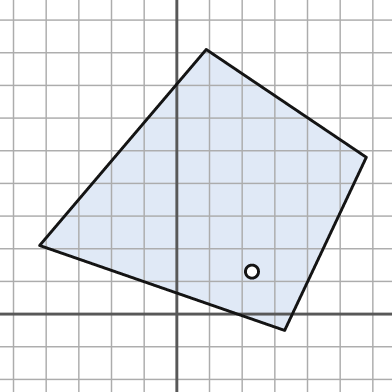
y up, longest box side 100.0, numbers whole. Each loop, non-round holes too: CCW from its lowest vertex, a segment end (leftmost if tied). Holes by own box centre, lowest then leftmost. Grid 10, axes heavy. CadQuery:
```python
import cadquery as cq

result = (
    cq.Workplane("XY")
    .moveTo(33.0, -5.0)
    .lineTo(58.0, 48.0)
    .lineTo(9.0, 81.0)
    .lineTo(-42.0, 21.0)
    .close()
    .moveTo(23.0, 13.0)
    .circle(2.0)
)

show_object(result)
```